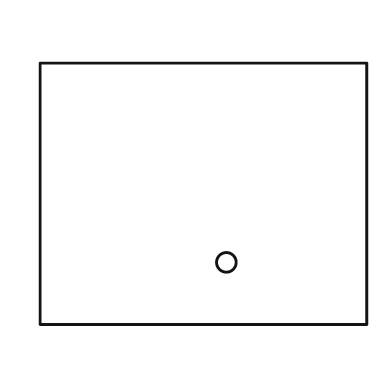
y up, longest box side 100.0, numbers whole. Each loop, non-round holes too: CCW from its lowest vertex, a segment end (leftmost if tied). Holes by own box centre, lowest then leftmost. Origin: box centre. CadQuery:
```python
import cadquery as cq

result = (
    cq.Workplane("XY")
    .moveTo(-50.0, -40.0)
    .lineTo(50.0, -40.0)
    .lineTo(50.0, 40.0)
    .lineTo(-50.0, 40.0)
    .close()
    .moveTo(7.0, -21.0)
    .circle(3.0)
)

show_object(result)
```